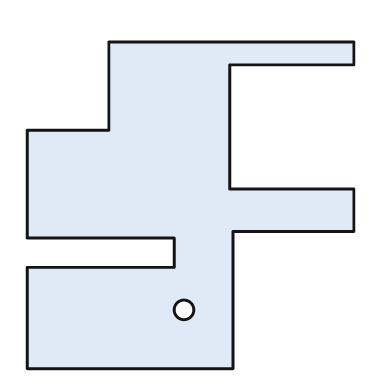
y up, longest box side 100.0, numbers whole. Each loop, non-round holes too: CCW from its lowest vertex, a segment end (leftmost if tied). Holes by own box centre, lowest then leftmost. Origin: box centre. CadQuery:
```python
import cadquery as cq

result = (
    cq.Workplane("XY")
    .moveTo(-50.0, -50.0)
    .lineTo(13.0, -50.0)
    .lineTo(13.0, -8.0)
    .lineTo(50.0, -8.0)
    .lineTo(50.0, 5.0)
    .lineTo(12.0, 5.0)
    .lineTo(12.0, 43.0)
    .lineTo(50.0, 43.0)
    .lineTo(50.0, 50.0)
    .lineTo(-25.0, 50.0)
    .lineTo(-25.0, 23.0)
    .lineTo(-50.0, 23.0)
    .lineTo(-50.0, -10.0)
    .lineTo(-5.0, -10.0)
    .lineTo(-5.0, -19.0)
    .lineTo(-50.0, -19.0)
    .close()
    .moveTo(-2.0, -32.0)
    .circle(3.0)
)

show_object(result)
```